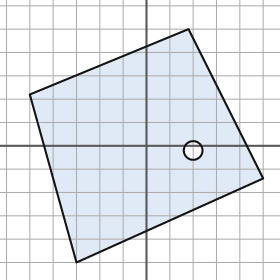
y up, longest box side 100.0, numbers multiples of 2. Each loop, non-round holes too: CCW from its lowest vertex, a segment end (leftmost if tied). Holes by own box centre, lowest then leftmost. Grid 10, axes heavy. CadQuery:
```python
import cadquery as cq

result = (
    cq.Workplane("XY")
    .moveTo(-30.0, -50.0)
    .lineTo(50.0, -14.0)
    .lineTo(18.0, 50.0)
    .lineTo(-50.0, 22.0)
    .close()
    .moveTo(20.0, -2.0)
    .circle(4.0)
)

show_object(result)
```